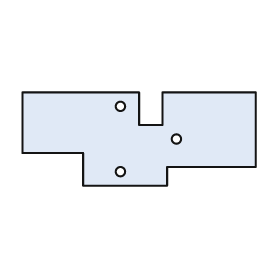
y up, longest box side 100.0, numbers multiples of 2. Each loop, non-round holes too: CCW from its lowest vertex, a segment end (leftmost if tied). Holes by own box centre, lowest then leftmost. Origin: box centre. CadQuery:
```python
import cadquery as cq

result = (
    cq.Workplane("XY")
    .moveTo(-24.0, -20.0)
    .lineTo(12.0, -20.0)
    .lineTo(12.0, -12.0)
    .lineTo(50.0, -12.0)
    .lineTo(50.0, 20.0)
    .lineTo(10.0, 20.0)
    .lineTo(10.0, 6.0)
    .lineTo(0.0, 6.0)
    .lineTo(0.0, 20.0)
    .lineTo(-50.0, 20.0)
    .lineTo(-50.0, -6.0)
    .lineTo(-24.0, -6.0)
    .close()
    .moveTo(-8.0, -14.0)
    .circle(2.0)
    .moveTo(16.0, 0.0)
    .circle(2.0)
    .moveTo(-8.0, 14.0)
    .circle(2.0)
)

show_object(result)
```